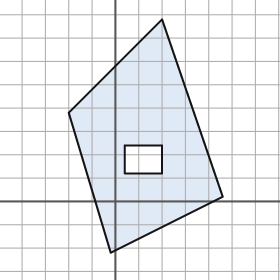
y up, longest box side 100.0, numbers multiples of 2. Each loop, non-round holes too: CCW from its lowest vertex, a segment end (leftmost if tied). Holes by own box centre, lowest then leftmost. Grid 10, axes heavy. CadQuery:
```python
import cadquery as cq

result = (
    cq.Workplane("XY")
    .moveTo(-2.0, -22.0)
    .lineTo(46.0, 2.0)
    .lineTo(20.0, 78.0)
    .lineTo(-20.0, 38.0)
    .close()
    .moveTo(4.0, 12.0)
    .lineTo(20.0, 12.0)
    .lineTo(20.0, 24.0)
    .lineTo(4.0, 24.0)
    .close()
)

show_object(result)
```